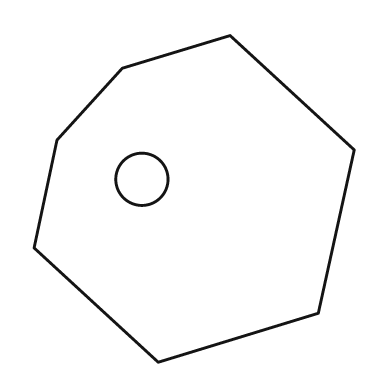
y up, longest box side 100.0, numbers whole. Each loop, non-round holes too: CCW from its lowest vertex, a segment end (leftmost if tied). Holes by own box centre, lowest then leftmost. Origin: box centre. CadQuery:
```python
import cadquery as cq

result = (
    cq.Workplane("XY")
    .moveTo(-11.0, -50.0)
    .lineTo(38.0, -35.0)
    .lineTo(49.0, 15.0)
    .lineTo(11.0, 50.0)
    .lineTo(-22.0, 40.0)
    .lineTo(-42.0, 18.0)
    .lineTo(-49.0, -15.0)
    .close()
    .moveTo(-16.0, 6.0)
    .circle(8.0)
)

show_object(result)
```